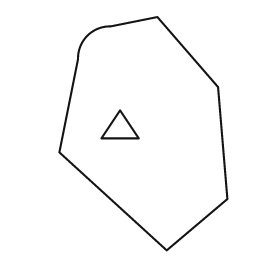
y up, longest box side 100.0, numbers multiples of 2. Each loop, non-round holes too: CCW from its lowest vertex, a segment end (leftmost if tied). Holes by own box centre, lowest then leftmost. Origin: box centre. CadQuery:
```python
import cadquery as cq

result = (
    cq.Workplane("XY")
    .moveTo(10.0, -50.0)
    .lineTo(36.0, -28.0)
    .lineTo(32.0, 20.0)
    .lineTo(6.0, 50.0)
    .lineTo(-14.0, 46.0)
    .threePointArc((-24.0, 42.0), (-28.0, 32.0))
    .lineTo(-36.0, -8.0)
    .close()
    .moveTo(-18.0, -2.0)
    .lineTo(-2.0, -2.0)
    .lineTo(-10.0, 10.0)
    .close()
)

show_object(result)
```